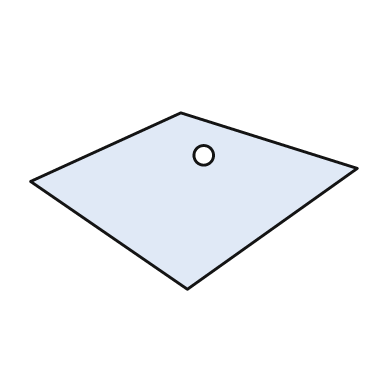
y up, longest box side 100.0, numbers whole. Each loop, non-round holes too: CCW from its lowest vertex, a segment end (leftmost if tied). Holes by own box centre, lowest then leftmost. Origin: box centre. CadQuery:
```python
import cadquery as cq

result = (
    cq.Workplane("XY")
    .moveTo(-2.0, -27.0)
    .lineTo(50.0, 10.0)
    .lineTo(-4.0, 27.0)
    .lineTo(-50.0, 6.0)
    .close()
    .moveTo(3.0, 14.0)
    .circle(3.0)
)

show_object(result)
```